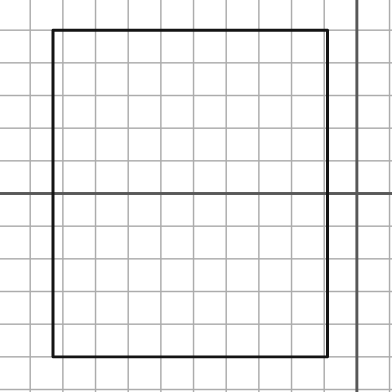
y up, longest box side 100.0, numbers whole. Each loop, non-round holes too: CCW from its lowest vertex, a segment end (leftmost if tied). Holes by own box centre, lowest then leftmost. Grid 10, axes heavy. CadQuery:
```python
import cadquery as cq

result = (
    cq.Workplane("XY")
    .moveTo(-93.0, -50.0)
    .lineTo(-9.0, -50.0)
    .lineTo(-9.0, 50.0)
    .lineTo(-93.0, 50.0)
    .close()
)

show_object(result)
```